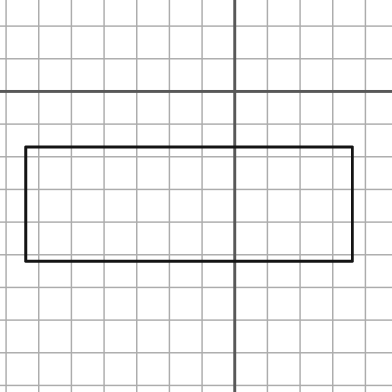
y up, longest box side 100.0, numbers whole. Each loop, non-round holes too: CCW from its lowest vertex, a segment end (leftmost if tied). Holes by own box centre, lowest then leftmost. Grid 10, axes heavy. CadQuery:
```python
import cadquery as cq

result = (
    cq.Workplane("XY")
    .moveTo(-64.0, -52.0)
    .lineTo(36.0, -52.0)
    .lineTo(36.0, -17.0)
    .lineTo(-64.0, -17.0)
    .close()
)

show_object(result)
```